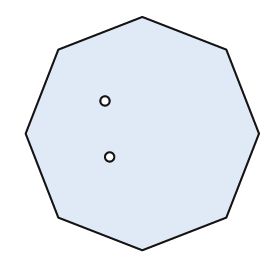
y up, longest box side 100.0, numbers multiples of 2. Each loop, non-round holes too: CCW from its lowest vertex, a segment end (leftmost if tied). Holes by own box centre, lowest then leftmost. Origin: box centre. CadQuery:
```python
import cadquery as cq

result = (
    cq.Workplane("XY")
    .moveTo(0.0, -50.0)
    .lineTo(36.0, -36.0)
    .lineTo(50.0, 0.0)
    .lineTo(36.0, 36.0)
    .lineTo(0.0, 50.0)
    .lineTo(-36.0, 36.0)
    .lineTo(-50.0, 0.0)
    .lineTo(-36.0, -36.0)
    .close()
    .moveTo(-14.0, -10.0)
    .circle(2.0)
    .moveTo(-16.0, 14.0)
    .circle(2.0)
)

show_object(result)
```